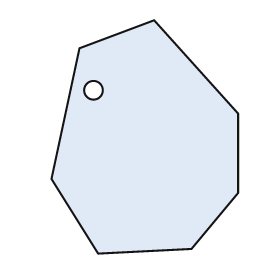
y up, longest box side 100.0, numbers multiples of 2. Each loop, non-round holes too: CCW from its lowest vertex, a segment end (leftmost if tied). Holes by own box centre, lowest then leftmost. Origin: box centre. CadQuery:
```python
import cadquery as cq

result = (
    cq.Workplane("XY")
    .moveTo(-20.0, -50.0)
    .lineTo(20.0, -48.0)
    .lineTo(40.0, -24.0)
    .lineTo(40.0, 10.0)
    .lineTo(4.0, 50.0)
    .lineTo(-28.0, 38.0)
    .lineTo(-40.0, -18.0)
    .close()
    .moveTo(-22.0, 20.0)
    .circle(4.0)
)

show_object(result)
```